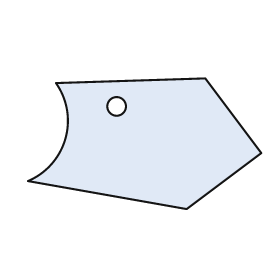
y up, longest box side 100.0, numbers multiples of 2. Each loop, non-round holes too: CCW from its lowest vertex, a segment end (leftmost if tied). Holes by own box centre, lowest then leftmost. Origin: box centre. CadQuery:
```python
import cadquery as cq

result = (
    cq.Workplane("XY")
    .moveTo(18.0, -28.0)
    .lineTo(50.0, -4.0)
    .lineTo(26.0, 28.0)
    .lineTo(-38.0, 26.0)
    .threePointArc((-34.0, 2.0), (-50.0, -16.0))
    .close()
    .moveTo(-12.0, 16.0)
    .circle(4.0)
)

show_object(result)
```